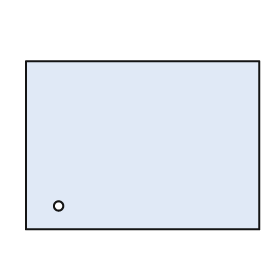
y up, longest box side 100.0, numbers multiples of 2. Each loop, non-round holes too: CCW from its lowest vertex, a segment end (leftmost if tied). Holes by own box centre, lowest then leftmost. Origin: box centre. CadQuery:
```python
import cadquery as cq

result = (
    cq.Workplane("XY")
    .moveTo(-50.0, -36.0)
    .lineTo(50.0, -36.0)
    .lineTo(50.0, 36.0)
    .lineTo(-50.0, 36.0)
    .close()
    .moveTo(-36.0, -26.0)
    .circle(2.0)
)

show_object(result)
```